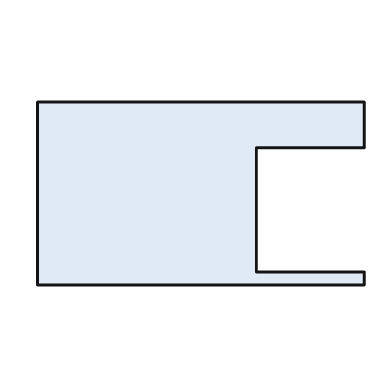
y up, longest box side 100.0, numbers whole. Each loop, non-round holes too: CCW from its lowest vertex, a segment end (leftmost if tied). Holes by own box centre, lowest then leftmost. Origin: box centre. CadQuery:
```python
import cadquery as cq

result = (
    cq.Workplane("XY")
    .moveTo(-50.0, -28.0)
    .lineTo(50.0, -28.0)
    .lineTo(50.0, -24.0)
    .lineTo(17.0, -24.0)
    .lineTo(17.0, 14.0)
    .lineTo(50.0, 14.0)
    .lineTo(50.0, 28.0)
    .lineTo(-50.0, 28.0)
    .close()
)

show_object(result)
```